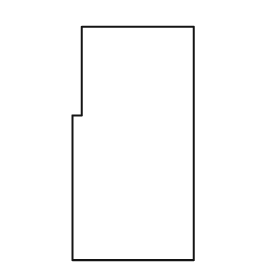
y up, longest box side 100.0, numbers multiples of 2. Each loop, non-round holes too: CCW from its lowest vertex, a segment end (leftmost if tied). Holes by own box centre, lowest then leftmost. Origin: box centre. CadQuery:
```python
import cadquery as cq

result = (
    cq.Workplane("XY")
    .moveTo(-26.0, -50.0)
    .lineTo(26.0, -50.0)
    .lineTo(26.0, 50.0)
    .lineTo(-22.0, 50.0)
    .lineTo(-22.0, 12.0)
    .lineTo(-26.0, 12.0)
    .close()
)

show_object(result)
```